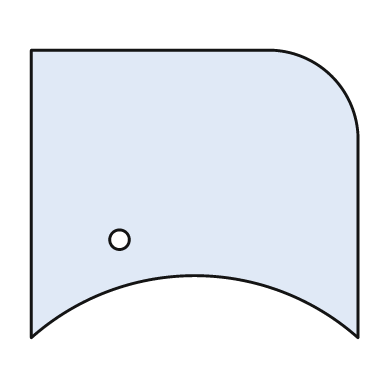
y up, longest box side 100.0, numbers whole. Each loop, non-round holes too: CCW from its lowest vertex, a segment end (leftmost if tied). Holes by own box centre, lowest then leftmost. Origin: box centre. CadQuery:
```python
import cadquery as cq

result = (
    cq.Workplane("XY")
    .moveTo(-50.0, -44.0)
    .threePointArc((0.0, -25.0), (50.0, -44.0))
    .lineTo(50.0, 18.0)
    .threePointArc((42.0, 36.0), (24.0, 44.0))
    .lineTo(-50.0, 44.0)
    .close()
    .moveTo(-23.0, -14.0)
    .circle(3.0)
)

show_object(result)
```